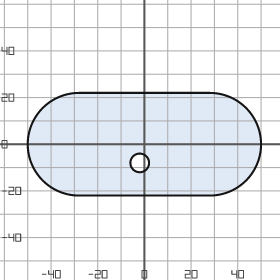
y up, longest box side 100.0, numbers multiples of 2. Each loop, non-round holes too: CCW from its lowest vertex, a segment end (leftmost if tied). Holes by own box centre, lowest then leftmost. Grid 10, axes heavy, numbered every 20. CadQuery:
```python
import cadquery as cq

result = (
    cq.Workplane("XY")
    .moveTo(-28.0, -22.0)
    .lineTo(28.0, -22.0)
    .threePointArc((50.0, 0.0), (28.0, 22.0))
    .lineTo(-28.0, 22.0)
    .threePointArc((-50.0, 0.0), (-28.0, -22.0))
    .close()
    .moveTo(-2.0, -8.0)
    .circle(4.0)
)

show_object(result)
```